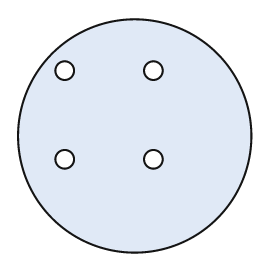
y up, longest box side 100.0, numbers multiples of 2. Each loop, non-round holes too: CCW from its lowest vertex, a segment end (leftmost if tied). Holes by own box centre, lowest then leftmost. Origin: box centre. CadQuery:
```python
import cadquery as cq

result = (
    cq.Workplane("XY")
    .moveTo(0.0, 0.0)
    .circle(50.0)
    .moveTo(-30.0, -10.0)
    .circle(4.0)
    .moveTo(8.0, -10.0)
    .circle(4.0)
    .moveTo(-30.0, 28.0)
    .circle(4.0)
    .moveTo(8.0, 28.0)
    .circle(4.0)
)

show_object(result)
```